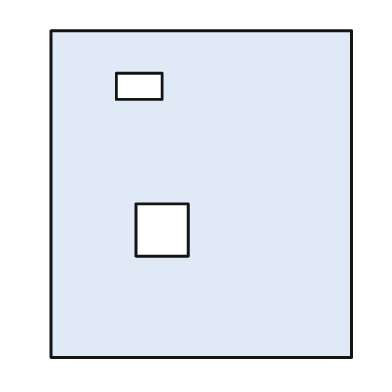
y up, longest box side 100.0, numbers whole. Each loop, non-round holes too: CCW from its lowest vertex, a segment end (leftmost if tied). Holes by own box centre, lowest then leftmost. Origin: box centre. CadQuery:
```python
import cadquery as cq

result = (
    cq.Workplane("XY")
    .moveTo(-46.0, -50.0)
    .lineTo(46.0, -50.0)
    .lineTo(46.0, 50.0)
    .lineTo(-46.0, 50.0)
    .close()
    .moveTo(-20.0, -19.0)
    .lineTo(-4.0, -19.0)
    .lineTo(-4.0, -3.0)
    .lineTo(-20.0, -3.0)
    .close()
    .moveTo(-26.0, 29.0)
    .lineTo(-12.0, 29.0)
    .lineTo(-12.0, 37.0)
    .lineTo(-26.0, 37.0)
    .close()
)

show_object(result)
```